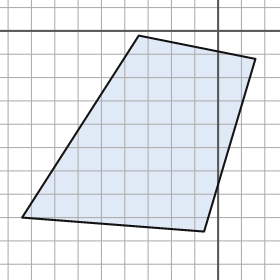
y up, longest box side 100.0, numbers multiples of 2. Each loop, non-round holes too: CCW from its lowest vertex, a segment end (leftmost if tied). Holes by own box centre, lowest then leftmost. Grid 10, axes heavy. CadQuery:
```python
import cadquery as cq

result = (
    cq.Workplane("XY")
    .moveTo(-6.0, -86.0)
    .lineTo(16.0, -12.0)
    .lineTo(-34.0, -2.0)
    .lineTo(-84.0, -80.0)
    .close()
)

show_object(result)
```